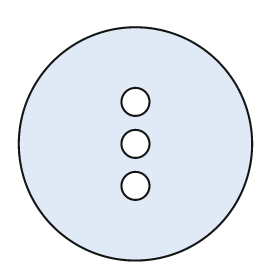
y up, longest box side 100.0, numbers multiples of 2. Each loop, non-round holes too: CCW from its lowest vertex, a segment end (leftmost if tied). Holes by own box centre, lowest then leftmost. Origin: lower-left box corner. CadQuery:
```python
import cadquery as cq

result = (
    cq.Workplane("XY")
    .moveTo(50.0, 50.0)
    .circle(50.0)
    .moveTo(50.0, 32.0)
    .circle(6.0)
    .moveTo(50.0, 50.0)
    .circle(6.0)
    .moveTo(50.0, 68.0)
    .circle(6.0)
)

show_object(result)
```